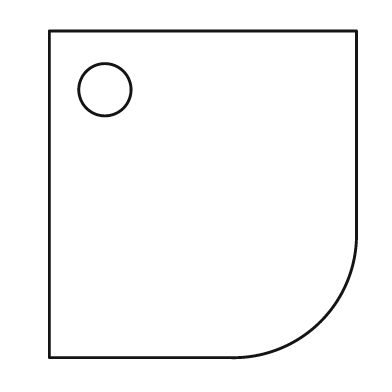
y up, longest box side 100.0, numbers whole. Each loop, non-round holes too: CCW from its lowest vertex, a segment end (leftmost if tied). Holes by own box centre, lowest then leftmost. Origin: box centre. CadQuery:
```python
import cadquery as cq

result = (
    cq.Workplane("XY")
    .moveTo(-47.0, -50.0)
    .lineTo(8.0, -50.0)
    .threePointArc((36.0, -39.0), (47.0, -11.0))
    .lineTo(47.0, 50.0)
    .lineTo(-47.0, 50.0)
    .close()
    .moveTo(-30.0, 32.0)
    .circle(8.0)
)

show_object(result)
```